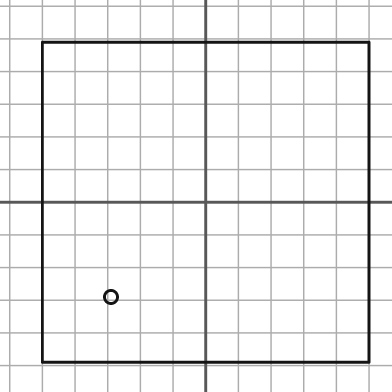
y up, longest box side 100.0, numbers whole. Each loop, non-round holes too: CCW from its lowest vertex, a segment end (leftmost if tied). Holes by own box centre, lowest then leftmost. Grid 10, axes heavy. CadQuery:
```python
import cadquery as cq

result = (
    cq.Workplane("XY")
    .moveTo(-50.0, -49.0)
    .lineTo(50.0, -49.0)
    .lineTo(50.0, 49.0)
    .lineTo(-50.0, 49.0)
    .close()
    .moveTo(-29.0, -29.0)
    .circle(2.0)
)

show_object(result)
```